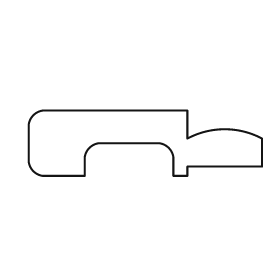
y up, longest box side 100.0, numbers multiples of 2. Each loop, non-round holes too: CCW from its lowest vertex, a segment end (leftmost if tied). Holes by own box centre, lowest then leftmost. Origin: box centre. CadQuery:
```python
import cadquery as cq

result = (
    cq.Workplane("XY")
    .moveTo(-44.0, -14.0)
    .lineTo(-26.0, -14.0)
    .lineTo(-26.0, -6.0)
    .threePointArc((-24.0, -2.0), (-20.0, 0.0))
    .lineTo(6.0, 0.0)
    .threePointArc((10.0, -2.0), (12.0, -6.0))
    .lineTo(12.0, -14.0)
    .lineTo(18.0, -14.0)
    .lineTo(18.0, -10.0)
    .lineTo(50.0, -10.0)
    .lineTo(50.0, 2.0)
    .threePointArc((34.0, 6.0), (18.0, 2.0))
    .lineTo(18.0, 14.0)
    .lineTo(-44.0, 14.0)
    .threePointArc((-48.0, 12.0), (-50.0, 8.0))
    .lineTo(-50.0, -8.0)
    .threePointArc((-48.0, -12.0), (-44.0, -14.0))
    .close()
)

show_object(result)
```